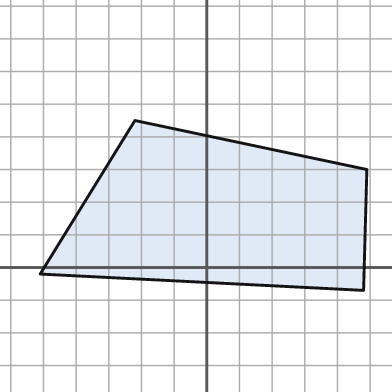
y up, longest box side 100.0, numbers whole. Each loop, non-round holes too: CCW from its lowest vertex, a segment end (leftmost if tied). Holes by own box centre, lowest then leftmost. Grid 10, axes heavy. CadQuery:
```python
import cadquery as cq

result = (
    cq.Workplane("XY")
    .moveTo(48.0, -7.0)
    .lineTo(49.0, 30.0)
    .lineTo(-22.0, 45.0)
    .lineTo(-51.0, -2.0)
    .close()
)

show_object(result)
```